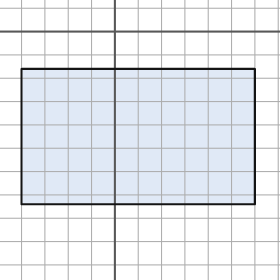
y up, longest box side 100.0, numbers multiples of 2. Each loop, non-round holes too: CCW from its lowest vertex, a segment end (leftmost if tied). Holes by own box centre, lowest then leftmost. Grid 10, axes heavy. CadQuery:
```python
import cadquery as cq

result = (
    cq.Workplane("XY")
    .moveTo(-40.0, -74.0)
    .lineTo(60.0, -74.0)
    .lineTo(60.0, -16.0)
    .lineTo(-40.0, -16.0)
    .close()
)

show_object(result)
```